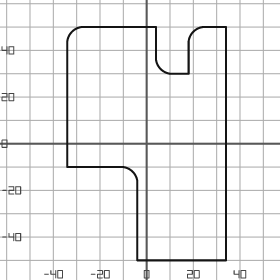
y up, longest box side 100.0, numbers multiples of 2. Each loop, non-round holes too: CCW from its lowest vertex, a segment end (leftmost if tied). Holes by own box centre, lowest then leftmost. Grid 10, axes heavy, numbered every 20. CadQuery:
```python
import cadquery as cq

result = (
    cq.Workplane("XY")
    .moveTo(-4.0, -50.0)
    .lineTo(34.0, -50.0)
    .lineTo(34.0, 50.0)
    .lineTo(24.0, 50.0)
    .threePointArc((20.0, 48.0), (18.0, 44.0))
    .lineTo(18.0, 30.0)
    .lineTo(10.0, 30.0)
    .threePointArc((6.0, 32.0), (4.0, 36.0))
    .lineTo(4.0, 50.0)
    .lineTo(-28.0, 50.0)
    .threePointArc((-32.0, 48.0), (-34.0, 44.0))
    .lineTo(-34.0, -10.0)
    .lineTo(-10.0, -10.0)
    .threePointArc((-6.0, -12.0), (-4.0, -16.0))
    .close()
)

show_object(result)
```